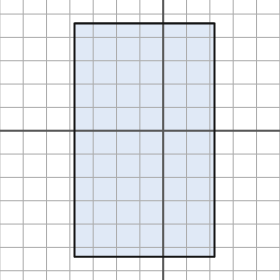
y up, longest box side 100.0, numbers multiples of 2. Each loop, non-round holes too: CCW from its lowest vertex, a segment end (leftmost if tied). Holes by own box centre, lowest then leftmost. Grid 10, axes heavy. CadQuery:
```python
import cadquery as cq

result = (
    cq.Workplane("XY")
    .moveTo(-38.0, -54.0)
    .lineTo(22.0, -54.0)
    .lineTo(22.0, 46.0)
    .lineTo(-38.0, 46.0)
    .close()
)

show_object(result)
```